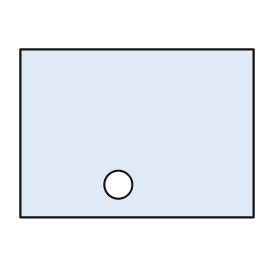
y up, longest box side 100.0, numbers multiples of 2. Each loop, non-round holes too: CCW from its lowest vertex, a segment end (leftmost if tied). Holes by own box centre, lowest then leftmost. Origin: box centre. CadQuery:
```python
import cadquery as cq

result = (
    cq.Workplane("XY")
    .moveTo(-50.0, -36.0)
    .lineTo(50.0, -36.0)
    .lineTo(50.0, 36.0)
    .lineTo(-50.0, 36.0)
    .close()
    .moveTo(-8.0, -22.0)
    .circle(6.0)
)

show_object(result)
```